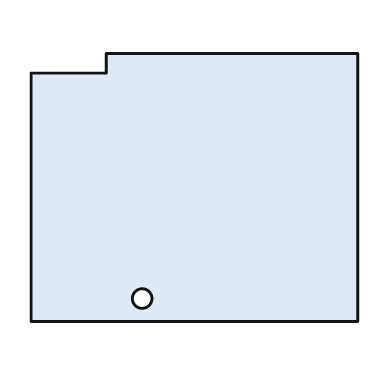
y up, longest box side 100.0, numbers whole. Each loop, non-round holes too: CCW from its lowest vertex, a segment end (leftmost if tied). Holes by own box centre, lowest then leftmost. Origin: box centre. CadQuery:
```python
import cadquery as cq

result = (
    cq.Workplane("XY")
    .moveTo(-50.0, -41.0)
    .lineTo(50.0, -41.0)
    .lineTo(50.0, 41.0)
    .lineTo(-27.0, 41.0)
    .lineTo(-27.0, 35.0)
    .lineTo(-50.0, 35.0)
    .close()
    .moveTo(-16.0, -34.0)
    .circle(3.0)
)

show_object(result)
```